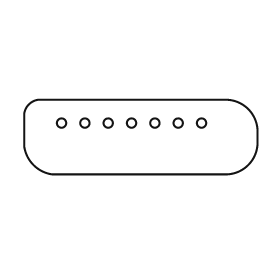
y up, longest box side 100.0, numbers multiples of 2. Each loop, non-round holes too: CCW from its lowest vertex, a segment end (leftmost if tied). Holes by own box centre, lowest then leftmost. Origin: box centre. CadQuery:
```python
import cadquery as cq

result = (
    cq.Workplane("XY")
    .moveTo(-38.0, -16.0)
    .lineTo(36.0, -16.0)
    .threePointArc((46.0, -12.0), (50.0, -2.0))
    .lineTo(50.0, 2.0)
    .threePointArc((46.0, 12.0), (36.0, 16.0))
    .lineTo(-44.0, 16.0)
    .threePointArc((-48.0, 14.0), (-50.0, 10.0))
    .lineTo(-50.0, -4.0)
    .threePointArc((-46.0, -12.0), (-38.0, -16.0))
    .close()
    .moveTo(-34.0, 6.0)
    .circle(2.0)
    .moveTo(-24.0, 6.0)
    .circle(2.0)
    .moveTo(-14.0, 6.0)
    .circle(2.0)
    .moveTo(-4.0, 6.0)
    .circle(2.0)
    .moveTo(6.0, 6.0)
    .circle(2.0)
    .moveTo(16.0, 6.0)
    .circle(2.0)
    .moveTo(26.0, 6.0)
    .circle(2.0)
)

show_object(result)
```